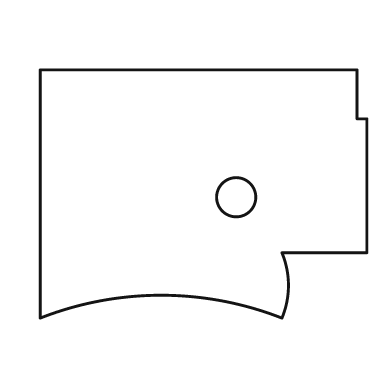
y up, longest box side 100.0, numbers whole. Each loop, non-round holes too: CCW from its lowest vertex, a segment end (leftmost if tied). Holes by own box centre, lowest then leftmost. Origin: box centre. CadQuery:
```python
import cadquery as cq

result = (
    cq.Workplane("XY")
    .moveTo(-50.0, -38.0)
    .threePointArc((-13.0, -31.0), (24.0, -38.0))
    .threePointArc((26.0, -28.0), (24.0, -18.0))
    .lineTo(50.0, -18.0)
    .lineTo(50.0, 23.0)
    .lineTo(47.0, 23.0)
    .lineTo(47.0, 38.0)
    .lineTo(-50.0, 38.0)
    .close()
    .moveTo(10.0, -1.0)
    .circle(6.0)
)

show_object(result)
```